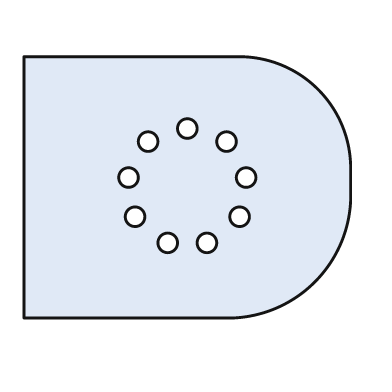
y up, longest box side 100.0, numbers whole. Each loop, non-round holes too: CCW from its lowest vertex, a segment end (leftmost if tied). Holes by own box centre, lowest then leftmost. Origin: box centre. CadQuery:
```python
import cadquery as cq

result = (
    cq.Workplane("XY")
    .moveTo(-50.0, -40.0)
    .lineTo(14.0, -40.0)
    .threePointArc((39.0, -29.0), (50.0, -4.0))
    .lineTo(50.0, 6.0)
    .threePointArc((40.0, 30.0), (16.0, 40.0))
    .lineTo(-50.0, 40.0)
    .close()
    .moveTo(-6.0, -17.0)
    .circle(3.0)
    .moveTo(6.0, -17.0)
    .circle(3.0)
    .moveTo(-16.0, -9.0)
    .circle(3.0)
    .moveTo(16.0, -9.0)
    .circle(3.0)
    .moveTo(-18.0, 3.0)
    .circle(3.0)
    .moveTo(18.0, 3.0)
    .circle(3.0)
    .moveTo(-12.0, 14.0)
    .circle(3.0)
    .moveTo(12.0, 14.0)
    .circle(3.0)
    .moveTo(0.0, 18.0)
    .circle(3.0)
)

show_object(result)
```